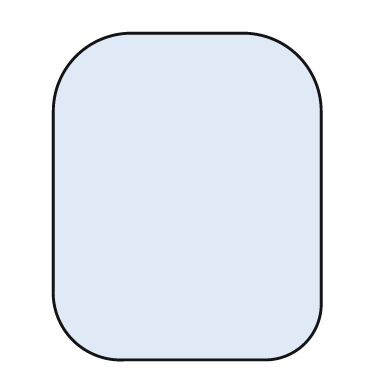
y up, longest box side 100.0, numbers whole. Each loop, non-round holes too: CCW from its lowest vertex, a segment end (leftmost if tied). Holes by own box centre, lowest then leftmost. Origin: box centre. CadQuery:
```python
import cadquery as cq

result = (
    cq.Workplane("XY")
    .moveTo(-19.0, -50.0)
    .lineTo(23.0, -50.0)
    .threePointArc((36.0, -45.0), (41.0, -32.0))
    .lineTo(41.0, 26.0)
    .threePointArc((34.0, 43.0), (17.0, 50.0))
    .lineTo(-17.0, 50.0)
    .threePointArc((-34.0, 43.0), (-41.0, 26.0))
    .lineTo(-41.0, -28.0)
    .threePointArc((-35.0, -44.0), (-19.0, -50.0))
    .close()
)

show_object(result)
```